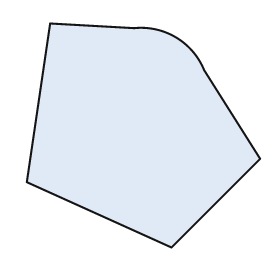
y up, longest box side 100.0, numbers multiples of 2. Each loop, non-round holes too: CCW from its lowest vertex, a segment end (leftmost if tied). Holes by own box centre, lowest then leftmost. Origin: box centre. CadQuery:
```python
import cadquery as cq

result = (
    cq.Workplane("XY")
    .moveTo(12.0, -48.0)
    .lineTo(50.0, -10.0)
    .lineTo(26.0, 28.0)
    .threePointArc((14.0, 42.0), (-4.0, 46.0))
    .lineTo(-40.0, 48.0)
    .lineTo(-50.0, -20.0)
    .close()
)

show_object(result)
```